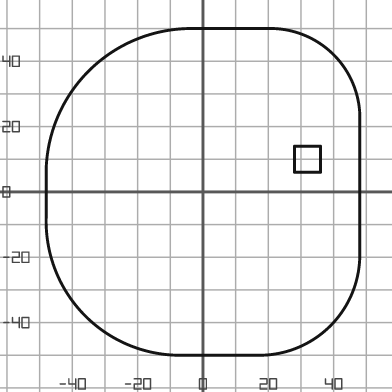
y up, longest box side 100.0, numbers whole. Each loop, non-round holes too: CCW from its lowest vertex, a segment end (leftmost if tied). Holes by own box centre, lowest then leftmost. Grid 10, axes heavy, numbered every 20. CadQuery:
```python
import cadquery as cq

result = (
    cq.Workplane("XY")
    .moveTo(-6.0, -50.0)
    .lineTo(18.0, -50.0)
    .threePointArc((39.0, -41.0), (48.0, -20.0))
    .lineTo(48.0, 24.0)
    .threePointArc((40.0, 42.0), (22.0, 50.0))
    .lineTo(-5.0, 50.0)
    .threePointArc((-35.0, 37.0), (-48.0, 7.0))
    .lineTo(-48.0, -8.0)
    .threePointArc((-36.0, -38.0), (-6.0, -50.0))
    .close()
    .moveTo(28.0, 6.0)
    .lineTo(36.0, 6.0)
    .lineTo(36.0, 14.0)
    .lineTo(28.0, 14.0)
    .close()
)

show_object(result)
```